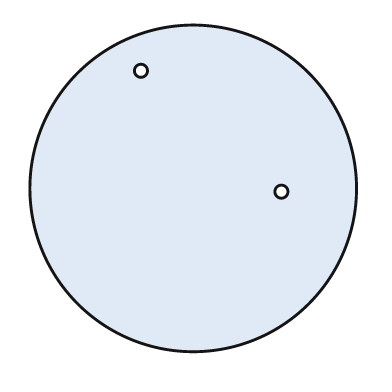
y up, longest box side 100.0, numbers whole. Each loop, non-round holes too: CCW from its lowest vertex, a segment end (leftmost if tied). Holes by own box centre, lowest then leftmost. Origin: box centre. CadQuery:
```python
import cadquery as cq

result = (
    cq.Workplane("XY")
    .moveTo(0.0, 0.0)
    .circle(50.0)
    .moveTo(27.0, -1.0)
    .circle(2.0)
    .moveTo(-16.0, 36.0)
    .circle(2.0)
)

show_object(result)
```